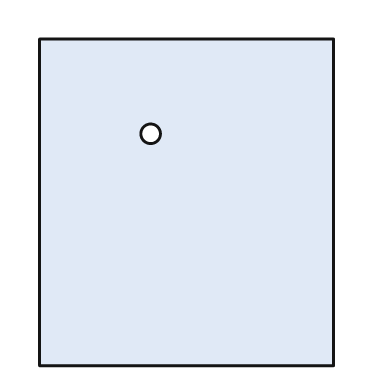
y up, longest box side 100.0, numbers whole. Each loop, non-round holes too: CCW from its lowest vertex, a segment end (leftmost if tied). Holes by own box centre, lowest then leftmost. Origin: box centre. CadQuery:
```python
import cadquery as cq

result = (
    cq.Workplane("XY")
    .moveTo(-45.0, -50.0)
    .lineTo(45.0, -50.0)
    .lineTo(45.0, 50.0)
    .lineTo(-45.0, 50.0)
    .close()
    .moveTo(-11.0, 21.0)
    .circle(3.0)
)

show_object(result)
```